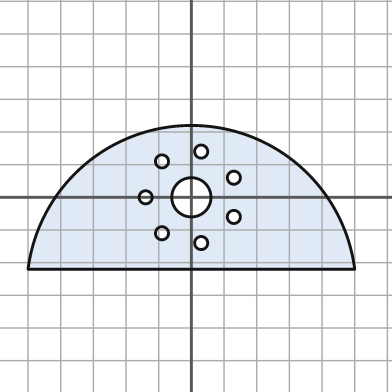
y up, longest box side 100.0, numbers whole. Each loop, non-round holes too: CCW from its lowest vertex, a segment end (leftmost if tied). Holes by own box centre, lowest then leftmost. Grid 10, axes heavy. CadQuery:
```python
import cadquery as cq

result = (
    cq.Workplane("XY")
    .moveTo(-50.0, -22.0)
    .lineTo(50.0, -22.0)
    .threePointArc((0.0, 22.0), (-50.0, -22.0))
    .close()
    .moveTo(3.0, -14.0)
    .circle(2.0)
    .moveTo(-9.0, -11.0)
    .circle(2.0)
    .moveTo(13.0, -6.0)
    .circle(2.0)
    .moveTo(-14.0, 0.0)
    .circle(2.0)
    .moveTo(0.0, 0.0)
    .circle(6.0)
    .moveTo(13.0, 6.0)
    .circle(2.0)
    .moveTo(-9.0, 11.0)
    .circle(2.0)
    .moveTo(3.0, 14.0)
    .circle(2.0)
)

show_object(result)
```